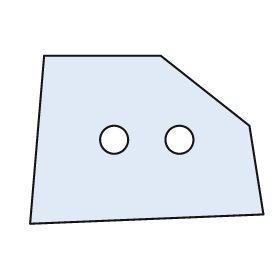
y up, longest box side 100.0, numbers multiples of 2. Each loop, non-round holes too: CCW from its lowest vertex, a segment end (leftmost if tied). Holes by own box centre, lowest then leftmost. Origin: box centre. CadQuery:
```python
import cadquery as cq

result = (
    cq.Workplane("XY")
    .moveTo(-50.0, -36.0)
    .lineTo(50.0, -32.0)
    .lineTo(44.0, 6.0)
    .lineTo(6.0, 36.0)
    .lineTo(-44.0, 36.0)
    .close()
    .moveTo(-14.0, 0.0)
    .circle(6.0)
    .moveTo(14.0, 0.0)
    .circle(6.0)
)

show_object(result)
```